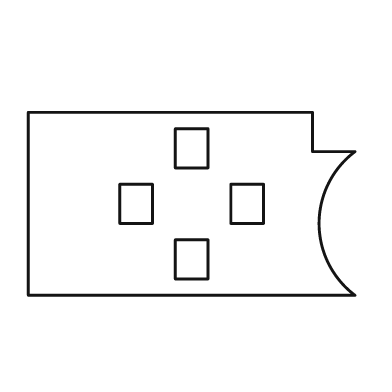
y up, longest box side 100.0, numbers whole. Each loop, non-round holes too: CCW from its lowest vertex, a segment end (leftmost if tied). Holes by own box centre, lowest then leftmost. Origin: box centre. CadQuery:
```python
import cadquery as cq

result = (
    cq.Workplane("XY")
    .moveTo(-50.0, -28.0)
    .lineTo(50.0, -28.0)
    .threePointArc((39.0, -6.0), (50.0, 16.0))
    .lineTo(37.0, 16.0)
    .lineTo(37.0, 28.0)
    .lineTo(-50.0, 28.0)
    .close()
    .moveTo(-5.0, -23.0)
    .lineTo(5.0, -23.0)
    .lineTo(5.0, -11.0)
    .lineTo(-5.0, -11.0)
    .close()
    .moveTo(-22.0, -6.0)
    .lineTo(-12.0, -6.0)
    .lineTo(-12.0, 6.0)
    .lineTo(-22.0, 6.0)
    .close()
    .moveTo(12.0, -6.0)
    .lineTo(22.0, -6.0)
    .lineTo(22.0, 6.0)
    .lineTo(12.0, 6.0)
    .close()
    .moveTo(-5.0, 11.0)
    .lineTo(5.0, 11.0)
    .lineTo(5.0, 23.0)
    .lineTo(-5.0, 23.0)
    .close()
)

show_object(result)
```